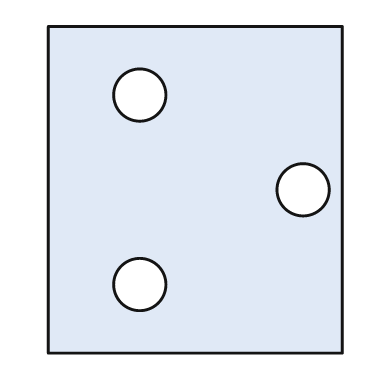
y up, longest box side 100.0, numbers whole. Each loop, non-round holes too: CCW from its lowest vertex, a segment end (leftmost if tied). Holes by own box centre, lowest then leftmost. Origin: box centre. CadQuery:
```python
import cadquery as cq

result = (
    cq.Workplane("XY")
    .moveTo(-45.0, -50.0)
    .lineTo(45.0, -50.0)
    .lineTo(45.0, 50.0)
    .lineTo(-45.0, 50.0)
    .close()
    .moveTo(-17.0, -29.0)
    .circle(8.0)
    .moveTo(33.0, 0.0)
    .circle(8.0)
    .moveTo(-17.0, 29.0)
    .circle(8.0)
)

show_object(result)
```